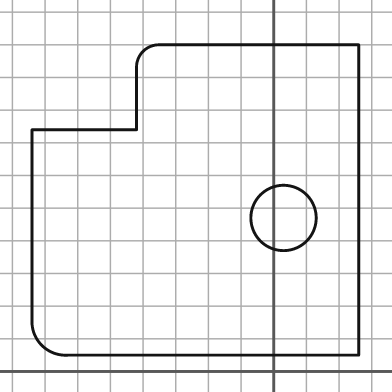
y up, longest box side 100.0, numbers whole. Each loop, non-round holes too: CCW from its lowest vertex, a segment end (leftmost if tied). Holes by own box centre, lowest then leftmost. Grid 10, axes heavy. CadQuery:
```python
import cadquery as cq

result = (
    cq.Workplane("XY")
    .moveTo(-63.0, 5.0)
    .lineTo(26.0, 5.0)
    .lineTo(26.0, 100.0)
    .lineTo(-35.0, 100.0)
    .threePointArc((-40.0, 98.0), (-42.0, 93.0))
    .lineTo(-42.0, 74.0)
    .lineTo(-74.0, 74.0)
    .lineTo(-74.0, 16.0)
    .threePointArc((-71.0, 8.0), (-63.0, 5.0))
    .close()
    .moveTo(3.0, 47.0)
    .circle(10.0)
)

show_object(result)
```